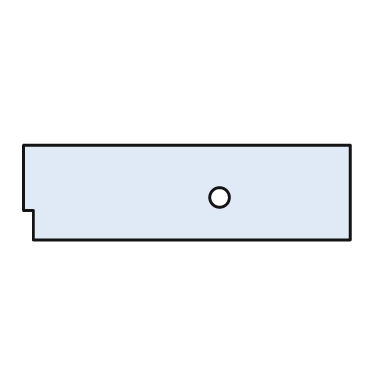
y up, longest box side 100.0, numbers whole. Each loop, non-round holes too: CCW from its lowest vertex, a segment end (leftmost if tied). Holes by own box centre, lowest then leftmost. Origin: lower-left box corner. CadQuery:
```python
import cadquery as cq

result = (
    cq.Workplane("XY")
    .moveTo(3.0, 0.0)
    .lineTo(100.0, 0.0)
    .lineTo(100.0, 29.0)
    .lineTo(0.0, 29.0)
    .lineTo(0.0, 9.0)
    .lineTo(3.0, 9.0)
    .close()
    .moveTo(60.0, 13.0)
    .circle(3.0)
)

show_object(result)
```